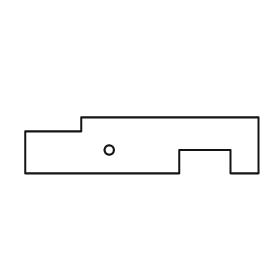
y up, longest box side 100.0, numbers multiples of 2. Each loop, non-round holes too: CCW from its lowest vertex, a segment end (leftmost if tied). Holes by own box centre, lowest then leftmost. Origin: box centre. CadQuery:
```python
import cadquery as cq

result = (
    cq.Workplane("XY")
    .moveTo(-50.0, -12.0)
    .lineTo(16.0, -12.0)
    .lineTo(16.0, -2.0)
    .lineTo(38.0, -2.0)
    .lineTo(38.0, -12.0)
    .lineTo(50.0, -12.0)
    .lineTo(50.0, 12.0)
    .lineTo(-26.0, 12.0)
    .lineTo(-26.0, 6.0)
    .lineTo(-50.0, 6.0)
    .close()
    .moveTo(-14.0, -2.0)
    .circle(2.0)
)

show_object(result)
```